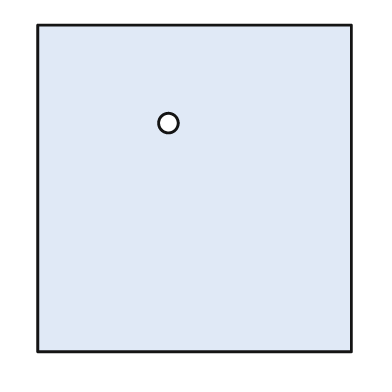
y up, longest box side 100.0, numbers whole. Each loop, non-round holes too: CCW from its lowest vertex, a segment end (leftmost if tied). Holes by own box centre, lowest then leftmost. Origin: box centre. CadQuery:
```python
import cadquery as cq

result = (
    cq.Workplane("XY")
    .moveTo(-48.0, -50.0)
    .lineTo(48.0, -50.0)
    .lineTo(48.0, 50.0)
    .lineTo(-48.0, 50.0)
    .close()
    .moveTo(-8.0, 20.0)
    .circle(3.0)
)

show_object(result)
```